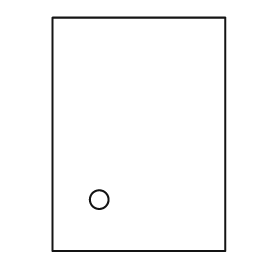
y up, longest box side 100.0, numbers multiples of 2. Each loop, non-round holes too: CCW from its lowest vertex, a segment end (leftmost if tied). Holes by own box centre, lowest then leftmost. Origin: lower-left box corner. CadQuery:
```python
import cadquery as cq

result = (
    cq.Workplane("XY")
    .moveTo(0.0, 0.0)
    .lineTo(74.0, 0.0)
    .lineTo(74.0, 100.0)
    .lineTo(0.0, 100.0)
    .close()
    .moveTo(20.0, 22.0)
    .circle(4.0)
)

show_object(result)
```